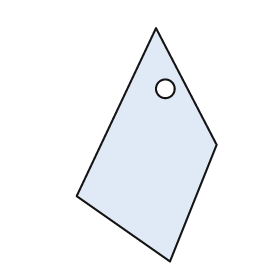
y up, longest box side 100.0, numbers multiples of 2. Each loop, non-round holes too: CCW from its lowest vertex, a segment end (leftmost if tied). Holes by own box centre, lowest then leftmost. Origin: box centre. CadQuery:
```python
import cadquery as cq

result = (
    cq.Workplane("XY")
    .moveTo(10.0, -50.0)
    .lineTo(30.0, 0.0)
    .lineTo(4.0, 50.0)
    .lineTo(-30.0, -22.0)
    .close()
    .moveTo(8.0, 24.0)
    .circle(4.0)
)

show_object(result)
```